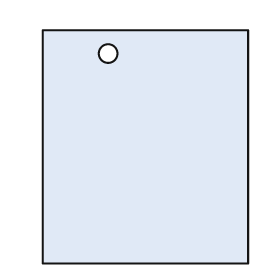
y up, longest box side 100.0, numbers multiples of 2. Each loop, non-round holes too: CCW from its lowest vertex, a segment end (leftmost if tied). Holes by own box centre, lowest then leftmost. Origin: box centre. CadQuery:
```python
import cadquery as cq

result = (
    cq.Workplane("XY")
    .moveTo(-44.0, -50.0)
    .lineTo(44.0, -50.0)
    .lineTo(44.0, 50.0)
    .lineTo(-44.0, 50.0)
    .close()
    .moveTo(-16.0, 40.0)
    .circle(4.0)
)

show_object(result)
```